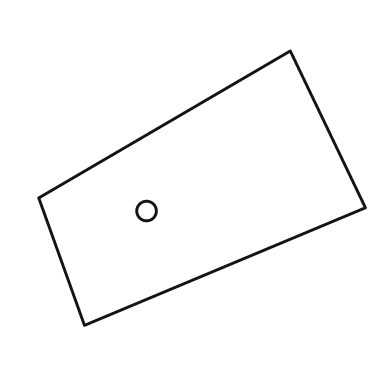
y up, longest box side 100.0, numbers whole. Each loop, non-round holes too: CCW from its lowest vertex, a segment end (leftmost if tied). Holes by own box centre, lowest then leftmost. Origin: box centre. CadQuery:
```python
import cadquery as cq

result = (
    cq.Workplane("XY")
    .moveTo(-36.0, -42.0)
    .lineTo(50.0, -6.0)
    .lineTo(27.0, 42.0)
    .lineTo(-50.0, -3.0)
    .close()
    .moveTo(-17.0, -7.0)
    .circle(3.0)
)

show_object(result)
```